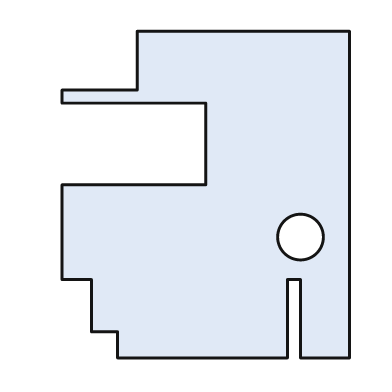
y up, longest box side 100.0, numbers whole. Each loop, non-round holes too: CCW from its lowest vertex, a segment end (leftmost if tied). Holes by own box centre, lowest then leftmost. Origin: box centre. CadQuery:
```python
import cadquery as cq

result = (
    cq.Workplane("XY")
    .moveTo(-27.0, -50.0)
    .lineTo(25.0, -50.0)
    .lineTo(25.0, -26.0)
    .lineTo(29.0, -26.0)
    .lineTo(29.0, -50.0)
    .lineTo(44.0, -50.0)
    .lineTo(44.0, 50.0)
    .lineTo(-21.0, 50.0)
    .lineTo(-21.0, 32.0)
    .lineTo(-44.0, 32.0)
    .lineTo(-44.0, 28.0)
    .lineTo(0.0, 28.0)
    .lineTo(0.0, 3.0)
    .lineTo(-44.0, 3.0)
    .lineTo(-44.0, -26.0)
    .lineTo(-35.0, -26.0)
    .lineTo(-35.0, -42.0)
    .lineTo(-27.0, -42.0)
    .close()
    .moveTo(29.0, -13.0)
    .circle(7.0)
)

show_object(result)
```